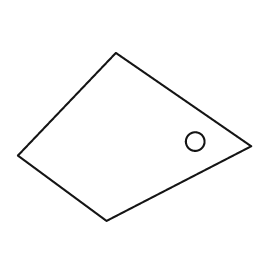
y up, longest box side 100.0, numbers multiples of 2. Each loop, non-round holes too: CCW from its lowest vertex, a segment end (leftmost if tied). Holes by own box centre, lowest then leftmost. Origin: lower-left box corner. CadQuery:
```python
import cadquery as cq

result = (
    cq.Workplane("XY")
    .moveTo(38.0, 0.0)
    .lineTo(100.0, 32.0)
    .lineTo(42.0, 72.0)
    .lineTo(0.0, 28.0)
    .close()
    .moveTo(76.0, 34.0)
    .circle(4.0)
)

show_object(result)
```